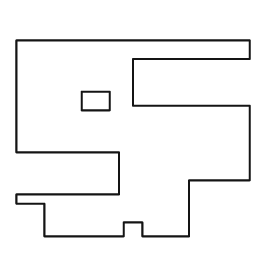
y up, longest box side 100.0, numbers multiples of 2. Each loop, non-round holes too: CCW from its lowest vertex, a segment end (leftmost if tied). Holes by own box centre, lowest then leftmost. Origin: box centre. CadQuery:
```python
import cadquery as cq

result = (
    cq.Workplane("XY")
    .moveTo(-38.0, -42.0)
    .lineTo(-4.0, -42.0)
    .lineTo(-4.0, -36.0)
    .lineTo(4.0, -36.0)
    .lineTo(4.0, -42.0)
    .lineTo(24.0, -42.0)
    .lineTo(24.0, -18.0)
    .lineTo(50.0, -18.0)
    .lineTo(50.0, 14.0)
    .lineTo(0.0, 14.0)
    .lineTo(0.0, 34.0)
    .lineTo(50.0, 34.0)
    .lineTo(50.0, 42.0)
    .lineTo(-50.0, 42.0)
    .lineTo(-50.0, -6.0)
    .lineTo(-6.0, -6.0)
    .lineTo(-6.0, -24.0)
    .lineTo(-50.0, -24.0)
    .lineTo(-50.0, -28.0)
    .lineTo(-38.0, -28.0)
    .close()
    .moveTo(-22.0, 12.0)
    .lineTo(-10.0, 12.0)
    .lineTo(-10.0, 20.0)
    .lineTo(-22.0, 20.0)
    .close()
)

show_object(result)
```